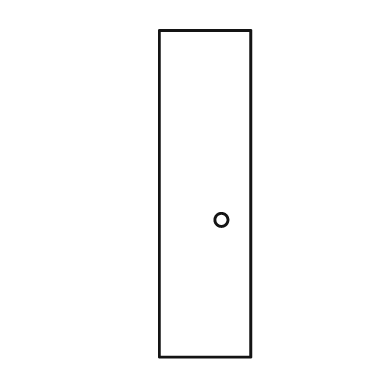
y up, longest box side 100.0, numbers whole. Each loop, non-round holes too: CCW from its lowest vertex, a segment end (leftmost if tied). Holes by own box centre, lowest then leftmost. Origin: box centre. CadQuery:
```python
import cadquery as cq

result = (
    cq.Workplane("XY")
    .moveTo(-14.0, -50.0)
    .lineTo(14.0, -50.0)
    .lineTo(14.0, 50.0)
    .lineTo(-14.0, 50.0)
    .close()
    .moveTo(5.0, -8.0)
    .circle(2.0)
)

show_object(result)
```